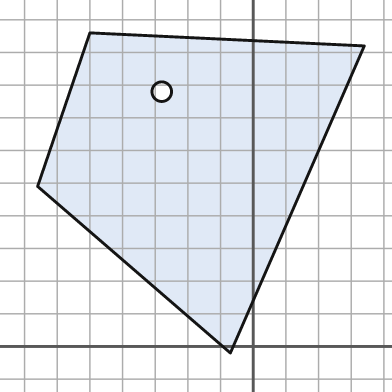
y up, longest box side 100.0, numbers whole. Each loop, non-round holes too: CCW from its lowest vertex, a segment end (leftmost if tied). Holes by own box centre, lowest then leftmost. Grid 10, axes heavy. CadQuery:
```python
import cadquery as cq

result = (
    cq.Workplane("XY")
    .moveTo(-7.0, -2.0)
    .lineTo(34.0, 92.0)
    .lineTo(-50.0, 96.0)
    .lineTo(-66.0, 49.0)
    .close()
    .moveTo(-28.0, 78.0)
    .circle(3.0)
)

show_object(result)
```